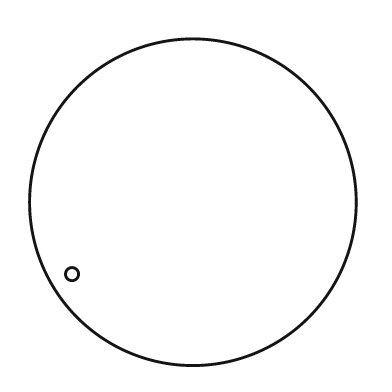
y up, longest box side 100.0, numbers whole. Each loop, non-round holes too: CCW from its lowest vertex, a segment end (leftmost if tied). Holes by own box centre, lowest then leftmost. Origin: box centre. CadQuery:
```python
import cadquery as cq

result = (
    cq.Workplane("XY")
    .moveTo(0.0, 0.0)
    .circle(50.0)
    .moveTo(-37.0, -22.0)
    .circle(2.0)
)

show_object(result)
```